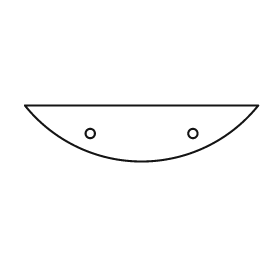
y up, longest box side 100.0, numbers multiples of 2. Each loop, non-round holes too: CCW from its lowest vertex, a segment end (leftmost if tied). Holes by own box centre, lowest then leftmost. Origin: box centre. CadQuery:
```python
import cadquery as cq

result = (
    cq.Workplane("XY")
    .moveTo(-50.0, 12.0)
    .threePointArc((0.0, -12.0), (50.0, 12.0))
    .close()
    .moveTo(-22.0, 0.0)
    .circle(2.0)
    .moveTo(22.0, 0.0)
    .circle(2.0)
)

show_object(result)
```